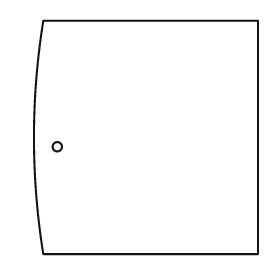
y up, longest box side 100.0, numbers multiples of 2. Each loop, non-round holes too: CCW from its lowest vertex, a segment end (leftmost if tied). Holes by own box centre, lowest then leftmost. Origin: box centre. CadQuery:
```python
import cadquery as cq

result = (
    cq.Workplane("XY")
    .moveTo(-44.0, -50.0)
    .lineTo(48.0, -50.0)
    .lineTo(48.0, 50.0)
    .lineTo(-44.0, 50.0)
    .threePointArc((-48.0, 0.0), (-44.0, -50.0))
    .close()
    .moveTo(-38.0, -4.0)
    .circle(2.0)
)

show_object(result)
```